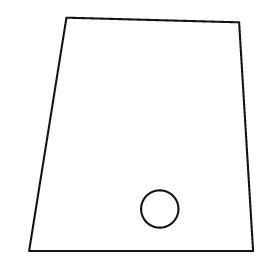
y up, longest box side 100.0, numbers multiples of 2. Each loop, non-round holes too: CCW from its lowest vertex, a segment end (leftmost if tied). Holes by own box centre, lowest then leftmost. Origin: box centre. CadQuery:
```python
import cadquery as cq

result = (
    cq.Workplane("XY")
    .moveTo(-48.0, -50.0)
    .lineTo(48.0, -50.0)
    .lineTo(42.0, 48.0)
    .lineTo(-32.0, 50.0)
    .close()
    .moveTo(8.0, -32.0)
    .circle(8.0)
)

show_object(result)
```